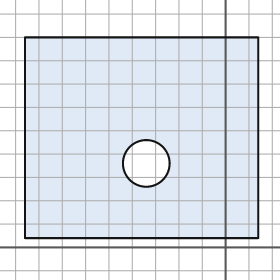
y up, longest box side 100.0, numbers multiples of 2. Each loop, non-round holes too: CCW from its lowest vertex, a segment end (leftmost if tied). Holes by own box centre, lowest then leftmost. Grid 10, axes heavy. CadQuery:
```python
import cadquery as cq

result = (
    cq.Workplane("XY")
    .moveTo(-86.0, 4.0)
    .lineTo(14.0, 4.0)
    .lineTo(14.0, 90.0)
    .lineTo(-86.0, 90.0)
    .close()
    .moveTo(-34.0, 36.0)
    .circle(10.0)
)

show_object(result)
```